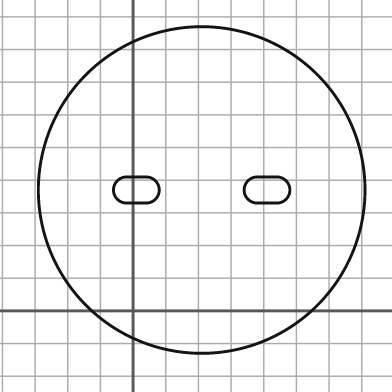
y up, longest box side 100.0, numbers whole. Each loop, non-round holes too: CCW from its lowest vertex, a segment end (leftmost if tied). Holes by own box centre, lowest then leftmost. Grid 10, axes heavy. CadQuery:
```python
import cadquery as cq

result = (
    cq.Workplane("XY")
    .moveTo(21.0, 37.0)
    .circle(50.0)
    .moveTo(-2.0, 33.0)
    .lineTo(4.0, 33.0)
    .threePointArc((8.0, 37.0), (4.0, 41.0))
    .lineTo(-2.0, 41.0)
    .threePointArc((-6.0, 37.0), (-2.0, 33.0))
    .close()
    .moveTo(38.0, 33.0)
    .lineTo(44.0, 33.0)
    .threePointArc((48.0, 37.0), (44.0, 41.0))
    .lineTo(38.0, 41.0)
    .threePointArc((34.0, 37.0), (38.0, 33.0))
    .close()
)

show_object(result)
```